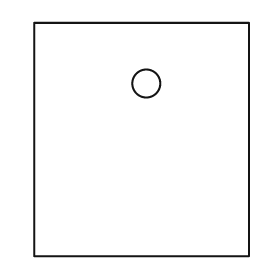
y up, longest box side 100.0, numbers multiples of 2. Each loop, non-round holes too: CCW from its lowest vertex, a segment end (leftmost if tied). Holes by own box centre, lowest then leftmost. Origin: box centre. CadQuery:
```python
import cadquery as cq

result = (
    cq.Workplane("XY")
    .moveTo(-46.0, -50.0)
    .lineTo(46.0, -50.0)
    .lineTo(46.0, 50.0)
    .lineTo(-46.0, 50.0)
    .close()
    .moveTo(2.0, 24.0)
    .circle(6.0)
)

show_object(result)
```